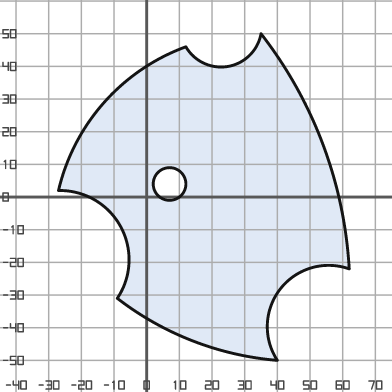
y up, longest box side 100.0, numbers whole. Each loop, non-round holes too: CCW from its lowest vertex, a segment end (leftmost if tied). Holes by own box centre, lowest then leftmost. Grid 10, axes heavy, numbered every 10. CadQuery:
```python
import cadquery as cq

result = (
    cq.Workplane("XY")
    .moveTo(40.0, -50.0)
    .threePointArc((41.0, -28.0), (62.0, -22.0))
    .threePointArc((54.0, 16.0), (35.0, 50.0))
    .threePointArc((25.0, 40.0), (12.0, 46.0))
    .threePointArc((-13.0, 29.0), (-27.0, 2.0))
    .threePointArc((-8.0, -9.0), (-9.0, -31.0))
    .threePointArc((14.0, -44.0), (40.0, -50.0))
    .close()
    .moveTo(7.0, 4.0)
    .circle(5.0)
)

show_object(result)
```